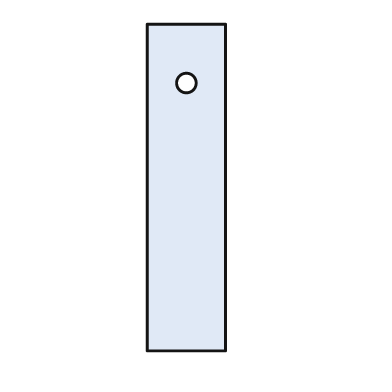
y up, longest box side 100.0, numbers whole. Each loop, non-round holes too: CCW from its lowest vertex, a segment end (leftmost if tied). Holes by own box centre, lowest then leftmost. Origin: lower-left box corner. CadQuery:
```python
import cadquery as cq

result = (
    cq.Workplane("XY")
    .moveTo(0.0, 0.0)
    .lineTo(24.0, 0.0)
    .lineTo(24.0, 100.0)
    .lineTo(0.0, 100.0)
    .close()
    .moveTo(12.0, 82.0)
    .circle(3.0)
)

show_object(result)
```